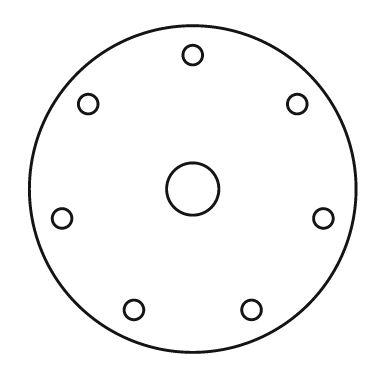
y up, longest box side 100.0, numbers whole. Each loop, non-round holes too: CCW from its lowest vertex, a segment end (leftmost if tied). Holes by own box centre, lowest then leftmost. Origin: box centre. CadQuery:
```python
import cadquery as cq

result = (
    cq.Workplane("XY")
    .moveTo(0.0, 0.0)
    .circle(50.0)
    .moveTo(-18.0, -37.0)
    .circle(3.0)
    .moveTo(18.0, -37.0)
    .circle(3.0)
    .moveTo(-40.0, -9.0)
    .circle(3.0)
    .moveTo(40.0, -9.0)
    .circle(3.0)
    .moveTo(0.0, 0.0)
    .circle(8.0)
    .moveTo(-32.0, 26.0)
    .circle(3.0)
    .moveTo(32.0, 26.0)
    .circle(3.0)
    .moveTo(0.0, 41.0)
    .circle(3.0)
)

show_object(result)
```